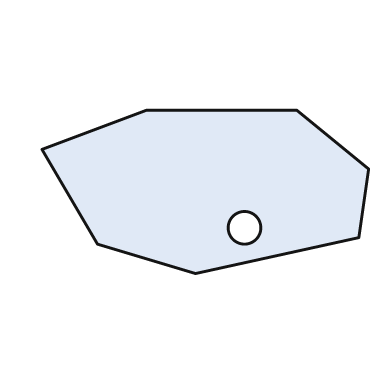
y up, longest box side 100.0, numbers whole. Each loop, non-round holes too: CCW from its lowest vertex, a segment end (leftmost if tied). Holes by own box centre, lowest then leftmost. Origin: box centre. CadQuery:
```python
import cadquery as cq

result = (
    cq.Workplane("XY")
    .moveTo(-3.0, -25.0)
    .lineTo(47.0, -14.0)
    .lineTo(50.0, 7.0)
    .lineTo(28.0, 25.0)
    .lineTo(-18.0, 25.0)
    .lineTo(-50.0, 13.0)
    .lineTo(-33.0, -16.0)
    .close()
    .moveTo(12.0, -11.0)
    .circle(5.0)
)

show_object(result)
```